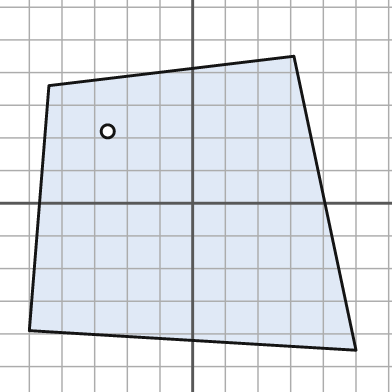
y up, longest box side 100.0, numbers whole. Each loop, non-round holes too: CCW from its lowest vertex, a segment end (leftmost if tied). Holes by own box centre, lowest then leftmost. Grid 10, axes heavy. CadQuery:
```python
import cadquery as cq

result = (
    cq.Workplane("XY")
    .moveTo(50.0, -45.0)
    .lineTo(31.0, 45.0)
    .lineTo(-44.0, 36.0)
    .lineTo(-50.0, -39.0)
    .close()
    .moveTo(-26.0, 22.0)
    .circle(2.0)
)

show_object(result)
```